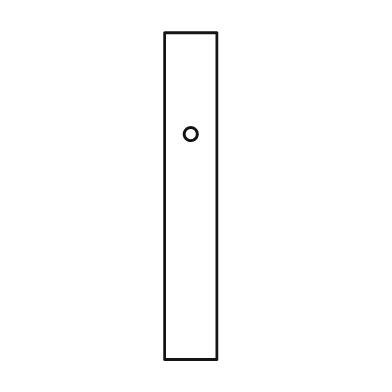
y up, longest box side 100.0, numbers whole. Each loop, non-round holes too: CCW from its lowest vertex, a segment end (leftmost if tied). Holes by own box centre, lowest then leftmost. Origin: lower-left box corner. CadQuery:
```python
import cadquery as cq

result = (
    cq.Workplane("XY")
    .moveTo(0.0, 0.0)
    .lineTo(16.0, 0.0)
    .lineTo(16.0, 100.0)
    .lineTo(0.0, 100.0)
    .close()
    .moveTo(8.0, 69.0)
    .circle(2.0)
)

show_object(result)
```